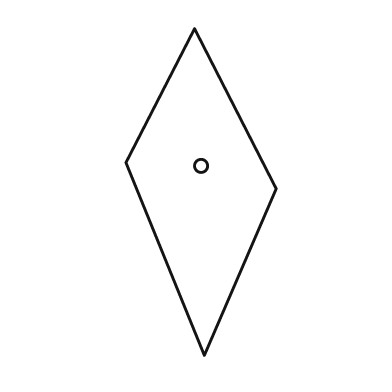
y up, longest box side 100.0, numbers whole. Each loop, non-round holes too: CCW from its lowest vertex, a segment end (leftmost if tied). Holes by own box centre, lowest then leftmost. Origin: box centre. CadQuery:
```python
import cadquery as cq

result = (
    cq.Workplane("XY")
    .moveTo(1.0, -50.0)
    .lineTo(23.0, 1.0)
    .lineTo(-2.0, 50.0)
    .lineTo(-23.0, 9.0)
    .close()
    .moveTo(0.0, 8.0)
    .circle(2.0)
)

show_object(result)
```